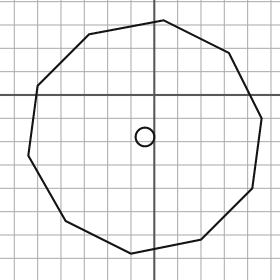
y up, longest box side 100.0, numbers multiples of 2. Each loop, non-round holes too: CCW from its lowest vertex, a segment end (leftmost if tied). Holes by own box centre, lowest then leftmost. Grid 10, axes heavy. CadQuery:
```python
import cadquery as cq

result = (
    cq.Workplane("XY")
    .moveTo(-10.0, -68.0)
    .lineTo(20.0, -62.0)
    .lineTo(42.0, -40.0)
    .lineTo(46.0, -10.0)
    .lineTo(32.0, 18.0)
    .lineTo(4.0, 32.0)
    .lineTo(-28.0, 26.0)
    .lineTo(-50.0, 4.0)
    .lineTo(-54.0, -26.0)
    .lineTo(-38.0, -54.0)
    .close()
    .moveTo(-4.0, -18.0)
    .circle(4.0)
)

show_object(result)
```